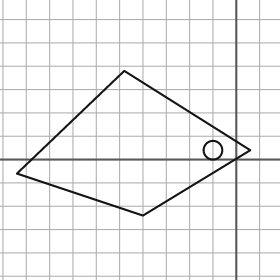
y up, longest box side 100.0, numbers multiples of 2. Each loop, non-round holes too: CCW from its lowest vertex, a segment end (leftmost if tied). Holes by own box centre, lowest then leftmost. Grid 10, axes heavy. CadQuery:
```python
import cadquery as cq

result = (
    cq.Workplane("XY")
    .moveTo(-40.0, -24.0)
    .lineTo(6.0, 4.0)
    .lineTo(-48.0, 38.0)
    .lineTo(-94.0, -6.0)
    .close()
    .moveTo(-10.0, 4.0)
    .circle(4.0)
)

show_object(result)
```